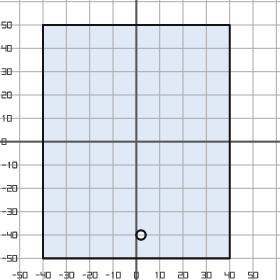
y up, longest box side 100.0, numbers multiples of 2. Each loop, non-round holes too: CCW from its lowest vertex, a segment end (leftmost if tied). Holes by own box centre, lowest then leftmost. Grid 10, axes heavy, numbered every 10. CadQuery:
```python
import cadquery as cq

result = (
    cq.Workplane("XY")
    .moveTo(-40.0, -50.0)
    .lineTo(40.0, -50.0)
    .lineTo(40.0, 50.0)
    .lineTo(-40.0, 50.0)
    .close()
    .moveTo(2.0, -40.0)
    .circle(2.0)
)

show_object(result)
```